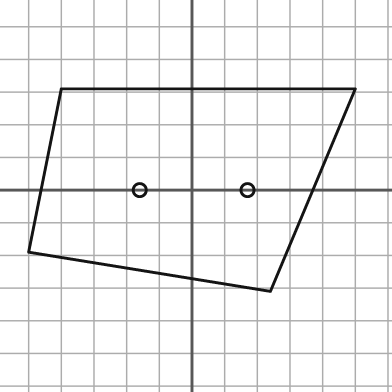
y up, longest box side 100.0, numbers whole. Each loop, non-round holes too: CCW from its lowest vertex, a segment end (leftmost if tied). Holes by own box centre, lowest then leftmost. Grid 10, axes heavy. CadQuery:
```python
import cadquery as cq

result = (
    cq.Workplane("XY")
    .moveTo(24.0, -31.0)
    .lineTo(50.0, 31.0)
    .lineTo(-40.0, 31.0)
    .lineTo(-50.0, -19.0)
    .close()
    .moveTo(-16.0, 0.0)
    .circle(2.0)
    .moveTo(17.0, 0.0)
    .circle(2.0)
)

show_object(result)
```